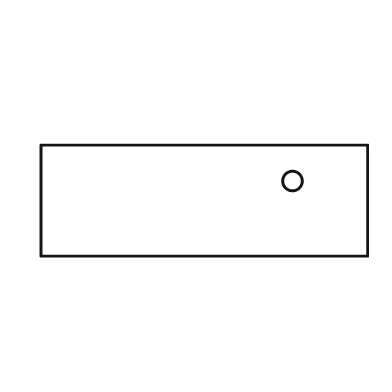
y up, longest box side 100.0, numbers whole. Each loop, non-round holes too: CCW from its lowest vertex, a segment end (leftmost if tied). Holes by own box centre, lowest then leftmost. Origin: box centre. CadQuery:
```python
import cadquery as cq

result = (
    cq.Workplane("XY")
    .moveTo(-50.0, -17.0)
    .lineTo(50.0, -17.0)
    .lineTo(50.0, 17.0)
    .lineTo(-50.0, 17.0)
    .close()
    .moveTo(27.0, 6.0)
    .circle(3.0)
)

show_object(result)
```